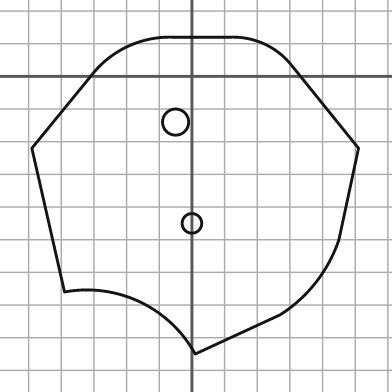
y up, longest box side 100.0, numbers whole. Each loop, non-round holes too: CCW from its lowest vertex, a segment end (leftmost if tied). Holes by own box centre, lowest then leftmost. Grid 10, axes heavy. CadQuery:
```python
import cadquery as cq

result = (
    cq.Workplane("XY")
    .moveTo(1.0, -85.0)
    .lineTo(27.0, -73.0)
    .threePointArc((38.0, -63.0), (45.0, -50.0))
    .lineTo(51.0, -22.0)
    .lineTo(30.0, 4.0)
    .threePointArc((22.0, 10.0), (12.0, 12.0))
    .lineTo(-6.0, 12.0)
    .threePointArc((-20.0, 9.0), (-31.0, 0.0))
    .lineTo(-49.0, -22.0)
    .lineTo(-39.0, -66.0)
    .threePointArc((-16.0, -69.0), (1.0, -85.0))
    .close()
    .moveTo(0.0, -45.0)
    .circle(3.0)
    .moveTo(-5.0, -14.0)
    .circle(4.0)
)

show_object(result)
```